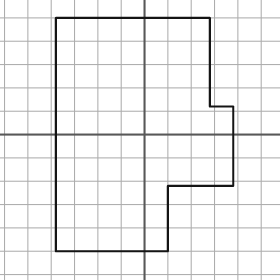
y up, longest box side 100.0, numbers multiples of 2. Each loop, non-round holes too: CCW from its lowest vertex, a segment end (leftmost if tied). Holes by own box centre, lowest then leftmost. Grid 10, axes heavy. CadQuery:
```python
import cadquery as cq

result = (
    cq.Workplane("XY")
    .moveTo(-38.0, -50.0)
    .lineTo(10.0, -50.0)
    .lineTo(10.0, -22.0)
    .lineTo(38.0, -22.0)
    .lineTo(38.0, 12.0)
    .lineTo(28.0, 12.0)
    .lineTo(28.0, 50.0)
    .lineTo(-38.0, 50.0)
    .close()
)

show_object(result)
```